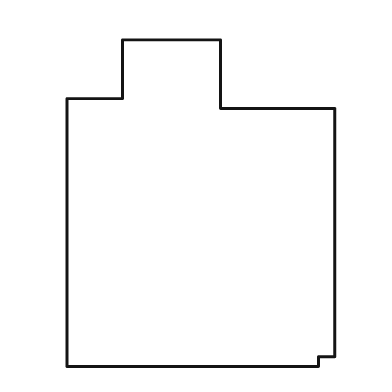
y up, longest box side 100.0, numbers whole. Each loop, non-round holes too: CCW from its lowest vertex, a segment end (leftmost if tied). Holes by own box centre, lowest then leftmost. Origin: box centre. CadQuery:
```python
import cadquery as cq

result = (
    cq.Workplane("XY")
    .moveTo(-41.0, -50.0)
    .lineTo(36.0, -50.0)
    .lineTo(36.0, -47.0)
    .lineTo(41.0, -47.0)
    .lineTo(41.0, 29.0)
    .lineTo(6.0, 29.0)
    .lineTo(6.0, 50.0)
    .lineTo(-24.0, 50.0)
    .lineTo(-24.0, 32.0)
    .lineTo(-41.0, 32.0)
    .close()
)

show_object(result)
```